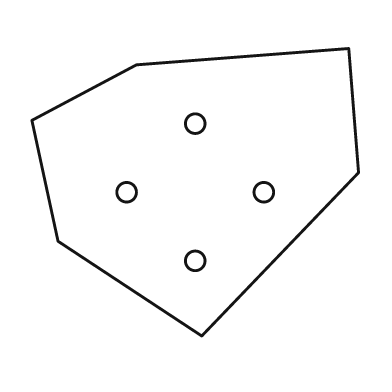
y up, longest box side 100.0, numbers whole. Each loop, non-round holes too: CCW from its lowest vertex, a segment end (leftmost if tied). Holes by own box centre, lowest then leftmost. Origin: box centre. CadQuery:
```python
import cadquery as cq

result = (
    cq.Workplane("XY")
    .moveTo(2.0, -44.0)
    .lineTo(50.0, 6.0)
    .lineTo(47.0, 44.0)
    .lineTo(-18.0, 39.0)
    .lineTo(-50.0, 22.0)
    .lineTo(-42.0, -15.0)
    .close()
    .moveTo(0.0, -21.0)
    .circle(3.0)
    .moveTo(-21.0, 0.0)
    .circle(3.0)
    .moveTo(21.0, 0.0)
    .circle(3.0)
    .moveTo(0.0, 21.0)
    .circle(3.0)
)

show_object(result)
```